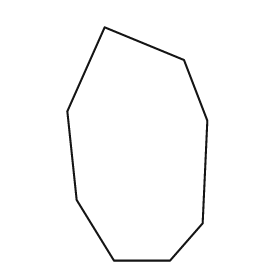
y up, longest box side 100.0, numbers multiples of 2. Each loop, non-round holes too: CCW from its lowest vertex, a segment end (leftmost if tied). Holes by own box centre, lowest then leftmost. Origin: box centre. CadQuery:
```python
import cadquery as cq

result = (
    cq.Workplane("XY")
    .moveTo(-10.0, -50.0)
    .lineTo(14.0, -50.0)
    .lineTo(28.0, -34.0)
    .lineTo(30.0, 10.0)
    .lineTo(20.0, 36.0)
    .lineTo(-14.0, 50.0)
    .lineTo(-30.0, 14.0)
    .lineTo(-26.0, -24.0)
    .close()
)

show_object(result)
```